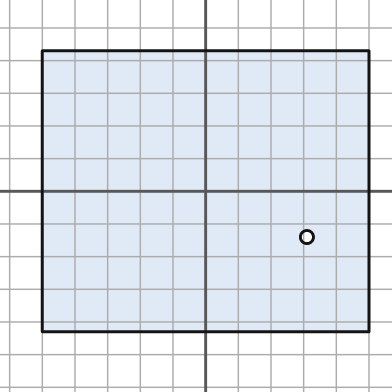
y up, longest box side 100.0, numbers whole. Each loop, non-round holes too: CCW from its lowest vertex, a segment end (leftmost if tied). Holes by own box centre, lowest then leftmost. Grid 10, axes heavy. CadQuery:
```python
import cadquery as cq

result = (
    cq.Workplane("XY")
    .moveTo(-50.0, -43.0)
    .lineTo(50.0, -43.0)
    .lineTo(50.0, 43.0)
    .lineTo(-50.0, 43.0)
    .close()
    .moveTo(31.0, -14.0)
    .circle(2.0)
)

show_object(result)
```